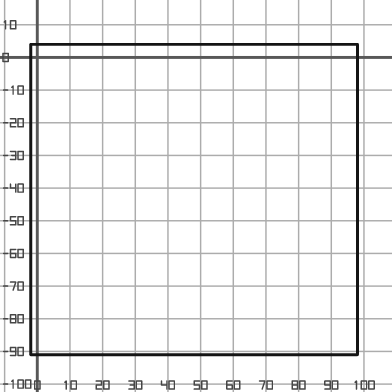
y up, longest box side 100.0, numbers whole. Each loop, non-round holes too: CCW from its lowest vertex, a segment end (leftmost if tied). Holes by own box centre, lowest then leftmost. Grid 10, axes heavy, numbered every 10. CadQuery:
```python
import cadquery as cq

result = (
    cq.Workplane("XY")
    .moveTo(-2.0, -91.0)
    .lineTo(98.0, -91.0)
    .lineTo(98.0, 4.0)
    .lineTo(-2.0, 4.0)
    .close()
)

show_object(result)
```